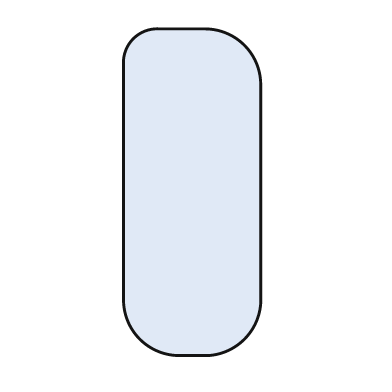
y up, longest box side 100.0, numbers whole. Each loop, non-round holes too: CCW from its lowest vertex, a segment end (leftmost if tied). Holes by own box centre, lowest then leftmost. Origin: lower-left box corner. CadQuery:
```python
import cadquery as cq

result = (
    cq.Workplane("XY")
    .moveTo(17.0, 0.0)
    .lineTo(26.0, 0.0)
    .threePointArc((37.0, 5.0), (42.0, 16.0))
    .lineTo(42.0, 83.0)
    .threePointArc((37.0, 95.0), (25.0, 100.0))
    .lineTo(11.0, 100.0)
    .threePointArc((3.0, 97.0), (0.0, 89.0))
    .lineTo(0.0, 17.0)
    .threePointArc((5.0, 5.0), (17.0, 0.0))
    .close()
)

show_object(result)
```